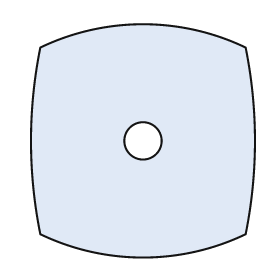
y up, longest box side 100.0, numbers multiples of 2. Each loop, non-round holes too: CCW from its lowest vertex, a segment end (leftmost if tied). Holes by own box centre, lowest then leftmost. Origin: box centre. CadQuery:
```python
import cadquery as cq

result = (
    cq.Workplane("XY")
    .moveTo(-44.0, -40.0)
    .threePointArc((0.0, -50.0), (44.0, -40.0))
    .threePointArc((48.0, 0.0), (44.0, 40.0))
    .threePointArc((0.0, 50.0), (-44.0, 40.0))
    .threePointArc((-48.0, 0.0), (-44.0, -40.0))
    .close()
    .moveTo(0.0, 0.0)
    .circle(8.0)
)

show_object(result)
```